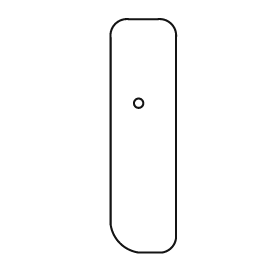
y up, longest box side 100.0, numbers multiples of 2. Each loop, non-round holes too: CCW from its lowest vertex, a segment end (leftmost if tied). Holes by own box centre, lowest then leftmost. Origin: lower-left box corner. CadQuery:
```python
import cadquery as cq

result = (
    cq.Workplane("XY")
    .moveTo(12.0, 0.0)
    .lineTo(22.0, 0.0)
    .threePointArc((26.0, 2.0), (28.0, 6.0))
    .lineTo(28.0, 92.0)
    .threePointArc((26.0, 98.0), (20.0, 100.0))
    .lineTo(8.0, 100.0)
    .threePointArc((2.0, 98.0), (0.0, 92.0))
    .lineTo(0.0, 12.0)
    .threePointArc((4.0, 4.0), (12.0, 0.0))
    .close()
    .moveTo(12.0, 64.0)
    .circle(2.0)
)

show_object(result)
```